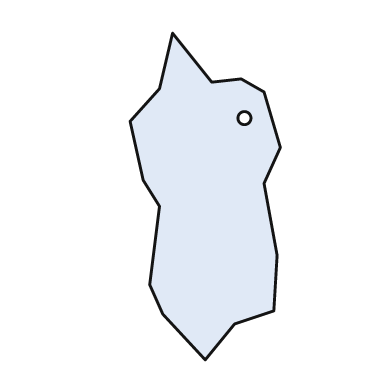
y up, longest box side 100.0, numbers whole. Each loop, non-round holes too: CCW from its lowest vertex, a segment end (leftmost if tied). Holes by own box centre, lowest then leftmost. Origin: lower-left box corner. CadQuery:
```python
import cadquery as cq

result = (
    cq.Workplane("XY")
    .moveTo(23.0, 0.0)
    .lineTo(32.0, 11.0)
    .lineTo(44.0, 15.0)
    .lineTo(45.0, 32.0)
    .lineTo(41.0, 54.0)
    .lineTo(46.0, 65.0)
    .lineTo(41.0, 82.0)
    .lineTo(34.0, 86.0)
    .lineTo(25.0, 85.0)
    .lineTo(13.0, 100.0)
    .lineTo(9.0, 83.0)
    .lineTo(0.0, 73.0)
    .lineTo(4.0, 55.0)
    .lineTo(9.0, 47.0)
    .lineTo(6.0, 23.0)
    .lineTo(10.0, 14.0)
    .close()
    .moveTo(35.0, 74.0)
    .circle(2.0)
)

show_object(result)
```